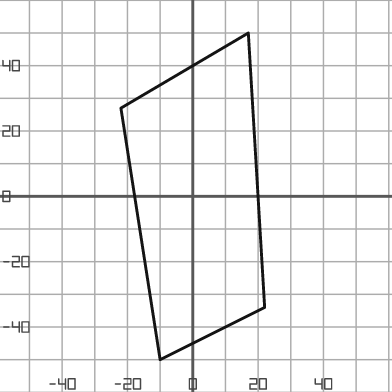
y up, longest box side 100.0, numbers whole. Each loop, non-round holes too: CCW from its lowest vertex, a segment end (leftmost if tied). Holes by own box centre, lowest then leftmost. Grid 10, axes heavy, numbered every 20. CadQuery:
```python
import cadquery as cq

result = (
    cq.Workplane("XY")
    .moveTo(-10.0, -50.0)
    .lineTo(22.0, -34.0)
    .lineTo(17.0, 50.0)
    .lineTo(-22.0, 27.0)
    .close()
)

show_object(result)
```